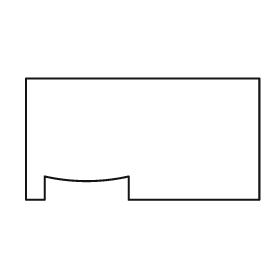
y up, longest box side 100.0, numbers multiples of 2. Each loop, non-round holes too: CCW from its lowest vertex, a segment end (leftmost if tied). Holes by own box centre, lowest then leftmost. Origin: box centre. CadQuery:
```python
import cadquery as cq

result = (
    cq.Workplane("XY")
    .moveTo(-50.0, -26.0)
    .lineTo(-42.0, -26.0)
    .lineTo(-42.0, -16.0)
    .threePointArc((-24.0, -18.0), (-6.0, -16.0))
    .lineTo(-6.0, -26.0)
    .lineTo(50.0, -26.0)
    .lineTo(50.0, 26.0)
    .lineTo(-50.0, 26.0)
    .close()
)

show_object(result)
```